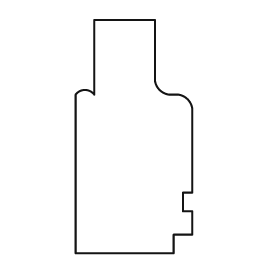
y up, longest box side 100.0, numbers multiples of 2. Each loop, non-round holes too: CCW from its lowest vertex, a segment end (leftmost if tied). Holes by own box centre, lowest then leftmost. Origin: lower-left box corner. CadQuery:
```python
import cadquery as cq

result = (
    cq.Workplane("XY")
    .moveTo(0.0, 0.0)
    .lineTo(42.0, 0.0)
    .lineTo(42.0, 8.0)
    .lineTo(50.0, 8.0)
    .lineTo(50.0, 18.0)
    .lineTo(46.0, 18.0)
    .lineTo(46.0, 26.0)
    .lineTo(50.0, 26.0)
    .lineTo(50.0, 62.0)
    .threePointArc((48.0, 66.0), (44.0, 68.0))
    .lineTo(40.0, 68.0)
    .threePointArc((36.0, 70.0), (34.0, 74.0))
    .lineTo(34.0, 100.0)
    .lineTo(8.0, 100.0)
    .lineTo(8.0, 68.0)
    .threePointArc((4.0, 70.0), (0.0, 68.0))
    .close()
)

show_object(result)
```